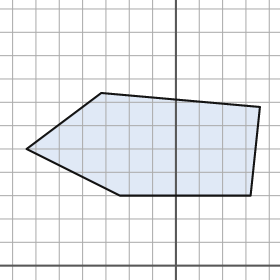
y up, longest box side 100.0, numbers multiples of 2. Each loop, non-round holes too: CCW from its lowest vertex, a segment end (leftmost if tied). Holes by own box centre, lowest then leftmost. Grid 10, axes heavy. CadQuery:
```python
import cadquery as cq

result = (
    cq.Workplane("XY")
    .moveTo(-24.0, 30.0)
    .lineTo(32.0, 30.0)
    .lineTo(36.0, 68.0)
    .lineTo(-32.0, 74.0)
    .lineTo(-64.0, 50.0)
    .close()
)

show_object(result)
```